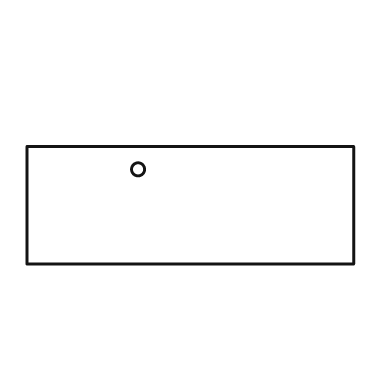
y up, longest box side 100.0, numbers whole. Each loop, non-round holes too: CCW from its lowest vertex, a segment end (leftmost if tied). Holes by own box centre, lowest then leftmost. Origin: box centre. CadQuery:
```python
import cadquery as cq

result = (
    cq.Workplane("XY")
    .moveTo(-50.0, -18.0)
    .lineTo(50.0, -18.0)
    .lineTo(50.0, 18.0)
    .lineTo(-50.0, 18.0)
    .close()
    .moveTo(-16.0, 11.0)
    .circle(2.0)
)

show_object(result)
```